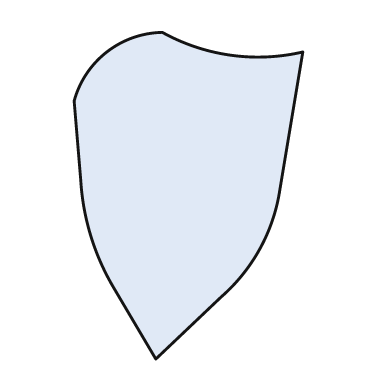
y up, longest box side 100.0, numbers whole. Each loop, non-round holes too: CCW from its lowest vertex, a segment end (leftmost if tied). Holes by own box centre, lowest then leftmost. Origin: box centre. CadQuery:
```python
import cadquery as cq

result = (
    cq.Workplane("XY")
    .moveTo(-10.0, -50.0)
    .lineTo(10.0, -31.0)
    .threePointArc((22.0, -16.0), (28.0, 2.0))
    .lineTo(35.0, 44.0)
    .threePointArc((13.0, 43.0), (-8.0, 50.0))
    .threePointArc((-25.0, 44.0), (-35.0, 29.0))
    .lineTo(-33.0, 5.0)
    .threePointArc((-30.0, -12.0), (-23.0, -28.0))
    .close()
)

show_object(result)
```